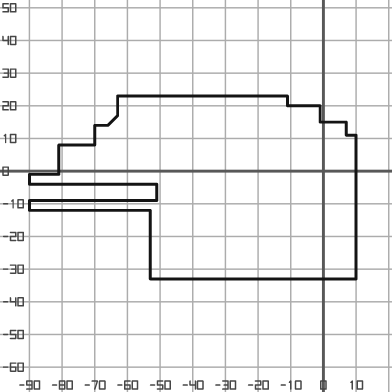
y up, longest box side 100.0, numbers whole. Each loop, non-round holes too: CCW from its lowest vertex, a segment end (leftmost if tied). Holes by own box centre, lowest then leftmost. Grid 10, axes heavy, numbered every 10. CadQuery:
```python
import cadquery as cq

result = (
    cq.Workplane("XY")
    .moveTo(-53.0, -33.0)
    .lineTo(10.0, -33.0)
    .lineTo(10.0, 11.0)
    .lineTo(7.0, 11.0)
    .lineTo(7.0, 15.0)
    .lineTo(-1.0, 15.0)
    .lineTo(-1.0, 20.0)
    .lineTo(-11.0, 20.0)
    .lineTo(-11.0, 23.0)
    .lineTo(-63.0, 23.0)
    .lineTo(-63.0, 17.0)
    .lineTo(-66.0, 14.0)
    .lineTo(-70.0, 14.0)
    .lineTo(-70.0, 8.0)
    .lineTo(-81.0, 8.0)
    .lineTo(-81.0, -1.0)
    .lineTo(-90.0, -1.0)
    .lineTo(-90.0, -4.0)
    .lineTo(-51.0, -4.0)
    .lineTo(-51.0, -9.0)
    .lineTo(-90.0, -9.0)
    .lineTo(-90.0, -12.0)
    .lineTo(-53.0, -12.0)
    .close()
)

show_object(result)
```